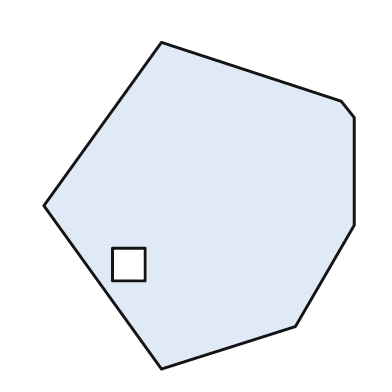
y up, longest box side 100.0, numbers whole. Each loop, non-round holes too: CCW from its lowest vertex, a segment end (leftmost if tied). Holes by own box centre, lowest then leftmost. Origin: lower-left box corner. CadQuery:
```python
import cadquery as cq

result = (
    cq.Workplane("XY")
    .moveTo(36.0, 0.0)
    .lineTo(77.0, 13.0)
    .lineTo(95.0, 44.0)
    .lineTo(95.0, 77.0)
    .lineTo(91.0, 82.0)
    .lineTo(36.0, 100.0)
    .lineTo(0.0, 50.0)
    .close()
    .moveTo(21.0, 27.0)
    .lineTo(31.0, 27.0)
    .lineTo(31.0, 37.0)
    .lineTo(21.0, 37.0)
    .close()
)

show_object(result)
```